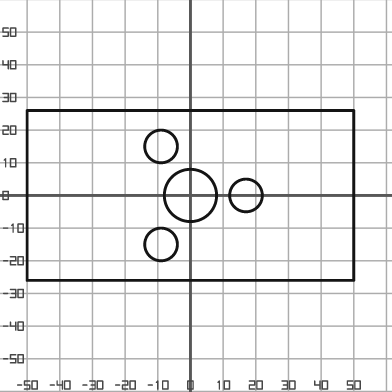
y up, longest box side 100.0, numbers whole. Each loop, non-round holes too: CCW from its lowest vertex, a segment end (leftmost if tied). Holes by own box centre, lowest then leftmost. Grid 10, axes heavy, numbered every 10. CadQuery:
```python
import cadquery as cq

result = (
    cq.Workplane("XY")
    .moveTo(-50.0, -26.0)
    .lineTo(50.0, -26.0)
    .lineTo(50.0, 26.0)
    .lineTo(-50.0, 26.0)
    .close()
    .moveTo(-9.0, -15.0)
    .circle(5.0)
    .moveTo(0.0, 0.0)
    .circle(8.0)
    .moveTo(17.0, 0.0)
    .circle(5.0)
    .moveTo(-9.0, 15.0)
    .circle(5.0)
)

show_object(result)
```